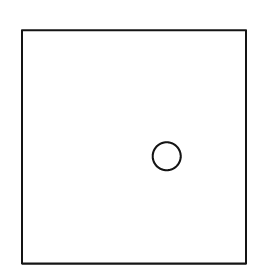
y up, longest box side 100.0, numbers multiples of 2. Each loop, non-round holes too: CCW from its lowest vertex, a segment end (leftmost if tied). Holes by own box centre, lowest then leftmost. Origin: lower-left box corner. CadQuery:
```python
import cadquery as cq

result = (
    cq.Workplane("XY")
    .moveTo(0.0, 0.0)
    .lineTo(96.0, 0.0)
    .lineTo(96.0, 100.0)
    .lineTo(0.0, 100.0)
    .close()
    .moveTo(62.0, 46.0)
    .circle(6.0)
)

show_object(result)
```